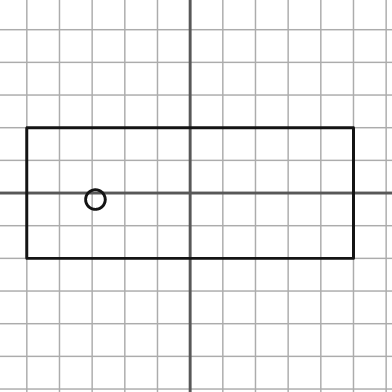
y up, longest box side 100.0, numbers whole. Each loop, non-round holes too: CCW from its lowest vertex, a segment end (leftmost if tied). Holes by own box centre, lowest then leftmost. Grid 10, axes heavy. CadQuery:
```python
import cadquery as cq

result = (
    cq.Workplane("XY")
    .moveTo(-50.0, -20.0)
    .lineTo(50.0, -20.0)
    .lineTo(50.0, 20.0)
    .lineTo(-50.0, 20.0)
    .close()
    .moveTo(-29.0, -2.0)
    .circle(3.0)
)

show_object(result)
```